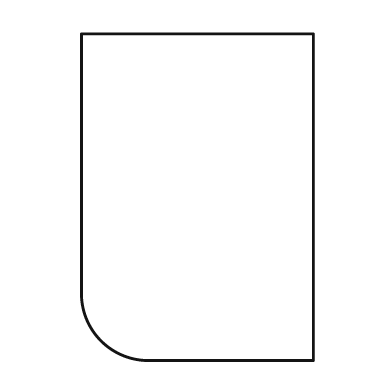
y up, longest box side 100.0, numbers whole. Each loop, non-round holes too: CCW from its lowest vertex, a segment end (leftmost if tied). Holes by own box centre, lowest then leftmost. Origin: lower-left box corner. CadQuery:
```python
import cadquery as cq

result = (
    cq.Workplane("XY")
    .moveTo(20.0, 0.0)
    .lineTo(71.0, 0.0)
    .lineTo(71.0, 100.0)
    .lineTo(0.0, 100.0)
    .lineTo(0.0, 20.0)
    .threePointArc((6.0, 6.0), (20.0, 0.0))
    .close()
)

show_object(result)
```